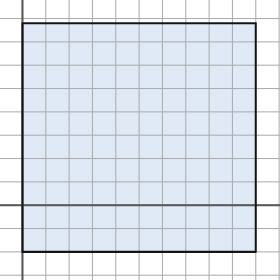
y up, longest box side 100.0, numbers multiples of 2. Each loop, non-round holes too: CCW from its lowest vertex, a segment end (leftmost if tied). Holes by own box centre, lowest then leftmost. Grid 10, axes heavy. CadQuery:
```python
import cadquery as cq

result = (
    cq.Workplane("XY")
    .moveTo(0.0, -20.0)
    .lineTo(100.0, -20.0)
    .lineTo(100.0, 78.0)
    .lineTo(0.0, 78.0)
    .close()
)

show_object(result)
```